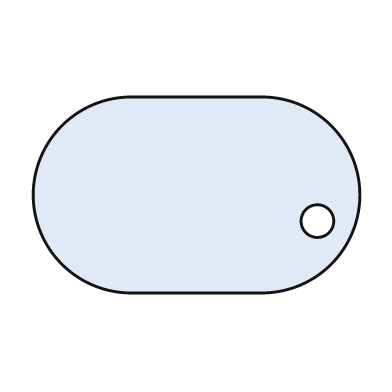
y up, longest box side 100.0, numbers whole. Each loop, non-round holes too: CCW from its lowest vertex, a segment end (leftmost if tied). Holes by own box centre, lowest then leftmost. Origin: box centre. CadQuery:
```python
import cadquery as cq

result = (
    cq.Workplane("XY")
    .moveTo(-20.0, -30.0)
    .lineTo(20.0, -30.0)
    .threePointArc((50.0, 0.0), (20.0, 30.0))
    .lineTo(-20.0, 30.0)
    .threePointArc((-50.0, 0.0), (-20.0, -30.0))
    .close()
    .moveTo(37.0, -8.0)
    .circle(5.0)
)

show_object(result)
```